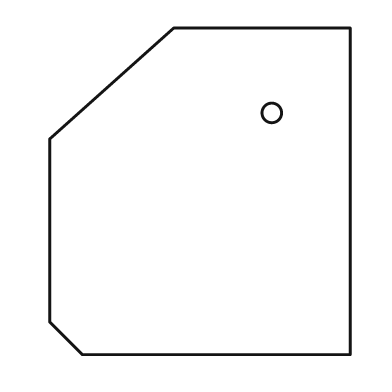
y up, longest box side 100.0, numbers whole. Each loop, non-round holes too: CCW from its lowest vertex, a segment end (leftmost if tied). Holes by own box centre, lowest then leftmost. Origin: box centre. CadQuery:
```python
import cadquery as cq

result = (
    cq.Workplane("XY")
    .moveTo(-36.0, -50.0)
    .lineTo(46.0, -50.0)
    .lineTo(46.0, 50.0)
    .lineTo(-8.0, 50.0)
    .lineTo(-46.0, 16.0)
    .lineTo(-46.0, -40.0)
    .close()
    .moveTo(22.0, 24.0)
    .circle(3.0)
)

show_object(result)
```